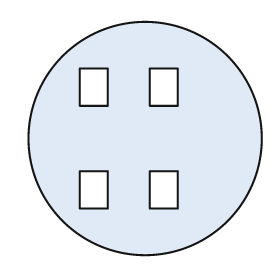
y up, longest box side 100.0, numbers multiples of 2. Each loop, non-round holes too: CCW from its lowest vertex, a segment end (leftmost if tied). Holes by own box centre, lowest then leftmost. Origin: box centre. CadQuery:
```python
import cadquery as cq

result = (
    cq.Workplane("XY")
    .moveTo(0.0, 0.0)
    .circle(50.0)
    .moveTo(-28.0, -30.0)
    .lineTo(-16.0, -30.0)
    .lineTo(-16.0, -14.0)
    .lineTo(-28.0, -14.0)
    .close()
    .moveTo(2.0, -30.0)
    .lineTo(14.0, -30.0)
    .lineTo(14.0, -14.0)
    .lineTo(2.0, -14.0)
    .close()
    .moveTo(-28.0, 14.0)
    .lineTo(-16.0, 14.0)
    .lineTo(-16.0, 30.0)
    .lineTo(-28.0, 30.0)
    .close()
    .moveTo(2.0, 14.0)
    .lineTo(14.0, 14.0)
    .lineTo(14.0, 30.0)
    .lineTo(2.0, 30.0)
    .close()
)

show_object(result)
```